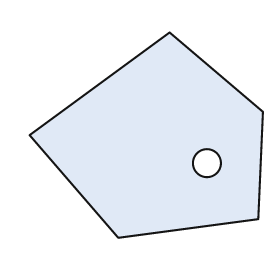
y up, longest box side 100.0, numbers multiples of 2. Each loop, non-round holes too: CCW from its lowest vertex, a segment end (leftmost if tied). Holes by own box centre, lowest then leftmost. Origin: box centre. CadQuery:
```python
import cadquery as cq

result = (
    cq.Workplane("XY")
    .moveTo(-12.0, -44.0)
    .lineTo(48.0, -36.0)
    .lineTo(50.0, 10.0)
    .lineTo(10.0, 44.0)
    .lineTo(-50.0, 0.0)
    .close()
    .moveTo(26.0, -12.0)
    .circle(6.0)
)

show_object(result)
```